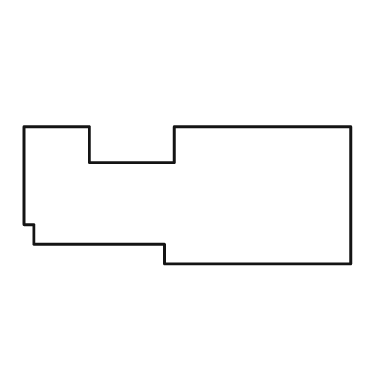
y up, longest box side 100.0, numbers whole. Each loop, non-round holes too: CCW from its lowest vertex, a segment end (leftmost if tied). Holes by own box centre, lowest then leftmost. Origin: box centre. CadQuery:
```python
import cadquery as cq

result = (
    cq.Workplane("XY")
    .moveTo(-7.0, -21.0)
    .lineTo(50.0, -21.0)
    .lineTo(50.0, 21.0)
    .lineTo(-4.0, 21.0)
    .lineTo(-4.0, 10.0)
    .lineTo(-30.0, 10.0)
    .lineTo(-30.0, 21.0)
    .lineTo(-50.0, 21.0)
    .lineTo(-50.0, -9.0)
    .lineTo(-47.0, -9.0)
    .lineTo(-47.0, -15.0)
    .lineTo(-7.0, -15.0)
    .close()
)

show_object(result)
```